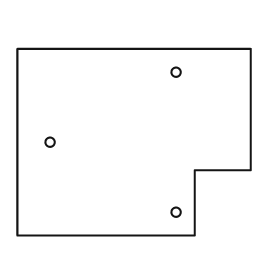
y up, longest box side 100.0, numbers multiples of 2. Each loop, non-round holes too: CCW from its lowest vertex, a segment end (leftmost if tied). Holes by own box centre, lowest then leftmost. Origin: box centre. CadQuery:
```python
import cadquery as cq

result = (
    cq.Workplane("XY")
    .moveTo(-50.0, -40.0)
    .lineTo(26.0, -40.0)
    .lineTo(26.0, -12.0)
    .lineTo(50.0, -12.0)
    .lineTo(50.0, 40.0)
    .lineTo(-50.0, 40.0)
    .close()
    .moveTo(18.0, -30.0)
    .circle(2.0)
    .moveTo(-36.0, 0.0)
    .circle(2.0)
    .moveTo(18.0, 30.0)
    .circle(2.0)
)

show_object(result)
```